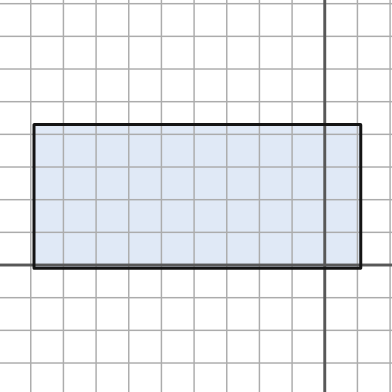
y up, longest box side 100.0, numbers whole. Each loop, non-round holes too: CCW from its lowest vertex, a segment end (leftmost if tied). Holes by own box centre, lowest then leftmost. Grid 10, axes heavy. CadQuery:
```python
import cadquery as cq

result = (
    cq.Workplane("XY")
    .moveTo(-89.0, -1.0)
    .lineTo(11.0, -1.0)
    .lineTo(11.0, 43.0)
    .lineTo(-89.0, 43.0)
    .close()
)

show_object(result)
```